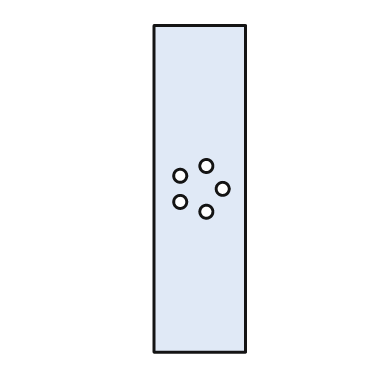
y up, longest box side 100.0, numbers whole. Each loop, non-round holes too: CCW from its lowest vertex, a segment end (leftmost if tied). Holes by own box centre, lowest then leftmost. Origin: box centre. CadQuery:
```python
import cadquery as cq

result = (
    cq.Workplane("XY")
    .moveTo(-14.0, -50.0)
    .lineTo(14.0, -50.0)
    .lineTo(14.0, 50.0)
    .lineTo(-14.0, 50.0)
    .close()
    .moveTo(2.0, -7.0)
    .circle(2.0)
    .moveTo(-6.0, -4.0)
    .circle(2.0)
    .moveTo(7.0, 0.0)
    .circle(2.0)
    .moveTo(-6.0, 4.0)
    .circle(2.0)
    .moveTo(2.0, 7.0)
    .circle(2.0)
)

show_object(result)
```